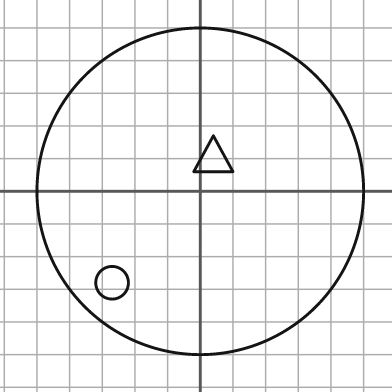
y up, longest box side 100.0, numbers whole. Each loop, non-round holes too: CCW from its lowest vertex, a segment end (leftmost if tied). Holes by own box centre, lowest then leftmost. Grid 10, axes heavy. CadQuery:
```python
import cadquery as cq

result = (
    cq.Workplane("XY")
    .moveTo(0.0, 0.0)
    .circle(50.0)
    .moveTo(-27.0, -28.0)
    .circle(5.0)
    .moveTo(-2.0, 6.0)
    .lineTo(10.0, 6.0)
    .lineTo(4.0, 17.0)
    .close()
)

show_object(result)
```